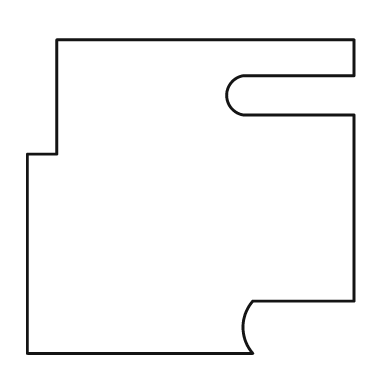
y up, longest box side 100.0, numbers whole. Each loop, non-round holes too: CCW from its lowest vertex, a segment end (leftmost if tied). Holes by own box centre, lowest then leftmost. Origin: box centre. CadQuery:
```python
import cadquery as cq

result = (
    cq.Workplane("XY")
    .moveTo(-50.0, -48.0)
    .lineTo(19.0, -48.0)
    .threePointArc((16.0, -40.0), (19.0, -32.0))
    .lineTo(50.0, -32.0)
    .lineTo(50.0, 25.0)
    .lineTo(16.0, 25.0)
    .threePointArc((11.0, 31.0), (16.0, 37.0))
    .lineTo(50.0, 37.0)
    .lineTo(50.0, 48.0)
    .lineTo(-41.0, 48.0)
    .lineTo(-41.0, 13.0)
    .lineTo(-50.0, 13.0)
    .close()
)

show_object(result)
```